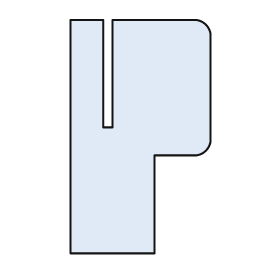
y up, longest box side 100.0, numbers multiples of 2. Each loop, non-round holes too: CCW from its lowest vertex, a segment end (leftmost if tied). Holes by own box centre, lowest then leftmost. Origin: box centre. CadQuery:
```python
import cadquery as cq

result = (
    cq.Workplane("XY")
    .moveTo(-30.0, -50.0)
    .lineTo(6.0, -50.0)
    .lineTo(6.0, -8.0)
    .lineTo(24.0, -8.0)
    .threePointArc((28.0, -6.0), (30.0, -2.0))
    .lineTo(30.0, 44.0)
    .threePointArc((28.0, 48.0), (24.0, 50.0))
    .lineTo(-12.0, 50.0)
    .lineTo(-12.0, 4.0)
    .lineTo(-16.0, 4.0)
    .lineTo(-16.0, 50.0)
    .lineTo(-30.0, 50.0)
    .close()
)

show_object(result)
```